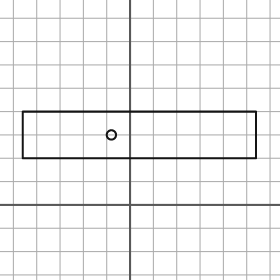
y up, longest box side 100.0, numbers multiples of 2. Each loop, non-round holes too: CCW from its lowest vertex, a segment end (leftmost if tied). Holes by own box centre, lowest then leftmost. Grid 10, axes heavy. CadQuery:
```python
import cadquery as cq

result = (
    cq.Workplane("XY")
    .moveTo(-46.0, 20.0)
    .lineTo(54.0, 20.0)
    .lineTo(54.0, 40.0)
    .lineTo(-46.0, 40.0)
    .close()
    .moveTo(-8.0, 30.0)
    .circle(2.0)
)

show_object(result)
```